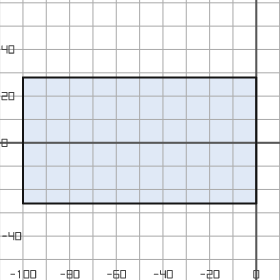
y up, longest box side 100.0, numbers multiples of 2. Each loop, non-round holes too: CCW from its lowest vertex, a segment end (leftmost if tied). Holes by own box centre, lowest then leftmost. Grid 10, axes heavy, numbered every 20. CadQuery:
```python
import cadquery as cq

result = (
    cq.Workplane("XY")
    .moveTo(-100.0, -26.0)
    .lineTo(0.0, -26.0)
    .lineTo(0.0, 28.0)
    .lineTo(-100.0, 28.0)
    .close()
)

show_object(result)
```